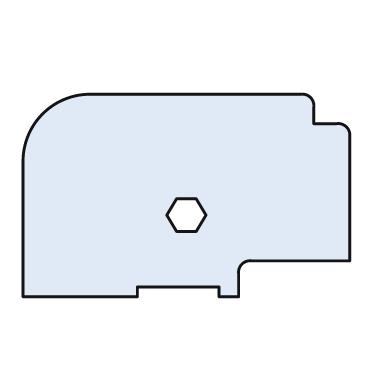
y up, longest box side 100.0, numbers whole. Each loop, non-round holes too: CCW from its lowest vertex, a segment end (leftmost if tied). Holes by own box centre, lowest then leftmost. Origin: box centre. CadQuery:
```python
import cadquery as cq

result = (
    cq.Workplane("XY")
    .moveTo(-50.0, -31.0)
    .lineTo(-15.0, -31.0)
    .lineTo(-15.0, -28.0)
    .lineTo(10.0, -28.0)
    .lineTo(10.0, -31.0)
    .lineTo(16.0, -31.0)
    .lineTo(16.0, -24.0)
    .threePointArc((17.0, -21.0), (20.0, -20.0))
    .lineTo(50.0, -20.0)
    .lineTo(50.0, 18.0)
    .threePointArc((49.0, 21.0), (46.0, 22.0))
    .lineTo(39.0, 22.0)
    .lineTo(39.0, 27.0)
    .threePointArc((38.0, 30.0), (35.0, 31.0))
    .lineTo(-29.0, 31.0)
    .threePointArc((-44.0, 25.0), (-50.0, 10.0))
    .close()
    .moveTo(-3.0, -11.0)
    .lineTo(3.0, -11.0)
    .lineTo(6.0, -6.0)
    .lineTo(3.0, -1.0)
    .lineTo(-3.0, -1.0)
    .lineTo(-6.0, -6.0)
    .close()
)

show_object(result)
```